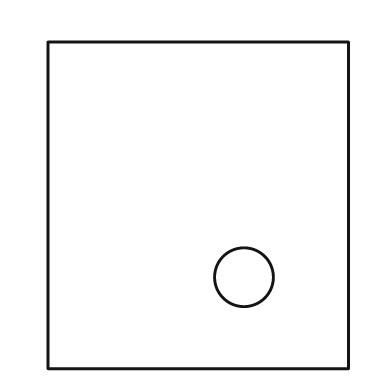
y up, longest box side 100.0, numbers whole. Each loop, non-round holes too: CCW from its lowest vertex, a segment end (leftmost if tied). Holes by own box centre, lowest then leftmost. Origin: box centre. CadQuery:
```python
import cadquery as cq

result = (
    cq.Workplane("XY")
    .moveTo(-46.0, -50.0)
    .lineTo(46.0, -50.0)
    .lineTo(46.0, 50.0)
    .lineTo(-46.0, 50.0)
    .close()
    .moveTo(14.0, -22.0)
    .circle(9.0)
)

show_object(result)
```